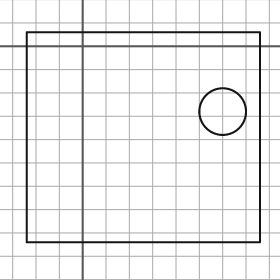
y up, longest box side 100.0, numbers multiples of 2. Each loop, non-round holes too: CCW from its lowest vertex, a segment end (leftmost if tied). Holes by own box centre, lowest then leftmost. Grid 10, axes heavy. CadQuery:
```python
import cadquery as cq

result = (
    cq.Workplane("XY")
    .moveTo(-24.0, -84.0)
    .lineTo(76.0, -84.0)
    .lineTo(76.0, 6.0)
    .lineTo(-24.0, 6.0)
    .close()
    .moveTo(60.0, -28.0)
    .circle(10.0)
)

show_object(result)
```